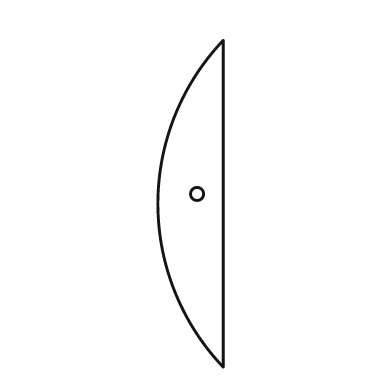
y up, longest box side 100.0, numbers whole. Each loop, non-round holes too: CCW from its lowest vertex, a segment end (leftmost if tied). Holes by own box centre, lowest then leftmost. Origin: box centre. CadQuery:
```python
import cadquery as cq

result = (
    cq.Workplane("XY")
    .moveTo(10.0, -50.0)
    .lineTo(10.0, 50.0)
    .threePointArc((-10.0, 0.0), (10.0, -50.0))
    .close()
    .moveTo(2.0, 3.0)
    .circle(2.0)
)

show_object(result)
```